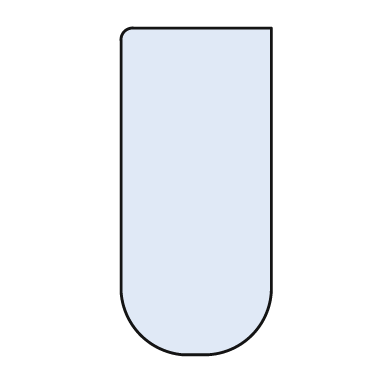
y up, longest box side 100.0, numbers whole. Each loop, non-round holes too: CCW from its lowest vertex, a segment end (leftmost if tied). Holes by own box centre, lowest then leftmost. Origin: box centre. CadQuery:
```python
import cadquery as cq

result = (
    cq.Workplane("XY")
    .moveTo(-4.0, -50.0)
    .lineTo(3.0, -50.0)
    .threePointArc((17.0, -44.0), (23.0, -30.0))
    .lineTo(23.0, 50.0)
    .lineTo(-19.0, 50.0)
    .threePointArc((-22.0, 49.0), (-23.0, 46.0))
    .lineTo(-23.0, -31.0)
    .threePointArc((-17.0, -44.0), (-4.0, -50.0))
    .close()
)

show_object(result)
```